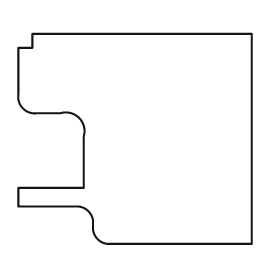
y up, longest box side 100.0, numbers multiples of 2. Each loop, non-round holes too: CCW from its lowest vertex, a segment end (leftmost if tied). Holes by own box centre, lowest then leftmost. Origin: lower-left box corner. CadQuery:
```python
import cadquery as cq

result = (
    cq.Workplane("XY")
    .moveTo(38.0, 0.0)
    .lineTo(100.0, 0.0)
    .lineTo(100.0, 90.0)
    .lineTo(6.0, 90.0)
    .lineTo(6.0, 84.0)
    .lineTo(0.0, 84.0)
    .lineTo(0.0, 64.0)
    .threePointArc((2.0, 58.0), (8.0, 56.0))
    .lineTo(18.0, 56.0)
    .threePointArc((26.0, 54.0), (28.0, 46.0))
    .lineTo(28.0, 24.0)
    .lineTo(0.0, 24.0)
    .lineTo(0.0, 16.0)
    .lineTo(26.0, 16.0)
    .threePointArc((30.0, 14.0), (32.0, 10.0))
    .lineTo(32.0, 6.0)
    .threePointArc((34.0, 2.0), (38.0, 0.0))
    .close()
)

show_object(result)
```